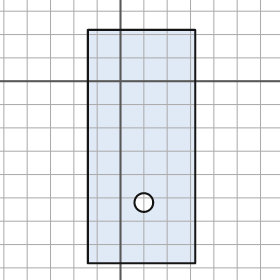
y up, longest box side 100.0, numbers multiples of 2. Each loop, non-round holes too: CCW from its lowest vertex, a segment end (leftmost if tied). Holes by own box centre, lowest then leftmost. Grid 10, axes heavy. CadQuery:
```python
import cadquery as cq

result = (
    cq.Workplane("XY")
    .moveTo(-14.0, -78.0)
    .lineTo(32.0, -78.0)
    .lineTo(32.0, 22.0)
    .lineTo(-14.0, 22.0)
    .close()
    .moveTo(10.0, -52.0)
    .circle(4.0)
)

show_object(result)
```